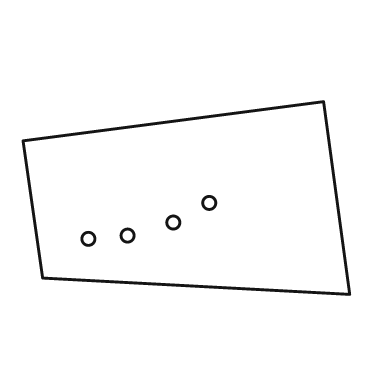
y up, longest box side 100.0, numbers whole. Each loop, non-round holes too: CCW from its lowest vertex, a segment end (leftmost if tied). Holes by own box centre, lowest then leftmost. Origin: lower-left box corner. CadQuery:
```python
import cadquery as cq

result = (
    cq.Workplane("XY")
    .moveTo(100.0, 0.0)
    .lineTo(92.0, 59.0)
    .lineTo(0.0, 47.0)
    .lineTo(6.0, 5.0)
    .close()
    .moveTo(20.0, 17.0)
    .circle(2.0)
    .moveTo(32.0, 18.0)
    .circle(2.0)
    .moveTo(46.0, 22.0)
    .circle(2.0)
    .moveTo(57.0, 28.0)
    .circle(2.0)
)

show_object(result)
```